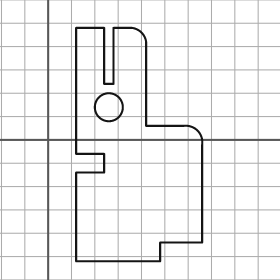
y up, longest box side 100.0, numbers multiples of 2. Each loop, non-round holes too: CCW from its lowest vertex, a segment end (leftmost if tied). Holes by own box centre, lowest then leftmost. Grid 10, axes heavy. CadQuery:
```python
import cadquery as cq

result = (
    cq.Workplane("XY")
    .moveTo(12.0, -52.0)
    .lineTo(48.0, -52.0)
    .lineTo(48.0, -44.0)
    .lineTo(66.0, -44.0)
    .lineTo(66.0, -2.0)
    .threePointArc((64.0, 4.0), (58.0, 6.0))
    .lineTo(42.0, 6.0)
    .lineTo(42.0, 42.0)
    .threePointArc((40.0, 46.0), (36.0, 48.0))
    .lineTo(28.0, 48.0)
    .lineTo(28.0, 24.0)
    .lineTo(24.0, 24.0)
    .lineTo(24.0, 48.0)
    .lineTo(12.0, 48.0)
    .lineTo(12.0, -6.0)
    .lineTo(24.0, -6.0)
    .lineTo(24.0, -14.0)
    .lineTo(12.0, -14.0)
    .close()
    .moveTo(26.0, 14.0)
    .circle(6.0)
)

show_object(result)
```